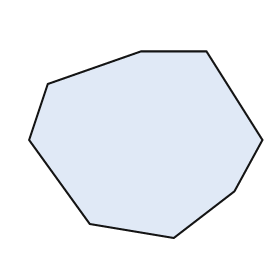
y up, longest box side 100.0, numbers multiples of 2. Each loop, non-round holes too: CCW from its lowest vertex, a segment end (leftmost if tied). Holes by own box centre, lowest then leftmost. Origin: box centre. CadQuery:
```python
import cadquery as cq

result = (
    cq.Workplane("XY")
    .moveTo(12.0, -40.0)
    .lineTo(38.0, -20.0)
    .lineTo(50.0, 2.0)
    .lineTo(26.0, 40.0)
    .lineTo(-2.0, 40.0)
    .lineTo(-42.0, 26.0)
    .lineTo(-50.0, 2.0)
    .lineTo(-24.0, -34.0)
    .close()
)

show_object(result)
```